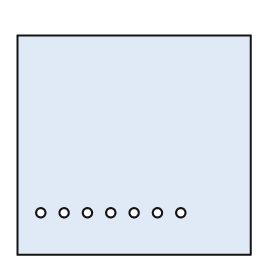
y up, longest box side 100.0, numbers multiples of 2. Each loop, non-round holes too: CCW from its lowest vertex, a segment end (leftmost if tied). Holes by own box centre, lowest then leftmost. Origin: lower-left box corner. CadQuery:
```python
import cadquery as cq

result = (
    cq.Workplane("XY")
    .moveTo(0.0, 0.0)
    .lineTo(100.0, 0.0)
    .lineTo(100.0, 94.0)
    .lineTo(0.0, 94.0)
    .close()
    .moveTo(10.0, 18.0)
    .circle(2.0)
    .moveTo(20.0, 18.0)
    .circle(2.0)
    .moveTo(30.0, 18.0)
    .circle(2.0)
    .moveTo(40.0, 18.0)
    .circle(2.0)
    .moveTo(50.0, 18.0)
    .circle(2.0)
    .moveTo(60.0, 18.0)
    .circle(2.0)
    .moveTo(70.0, 18.0)
    .circle(2.0)
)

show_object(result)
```